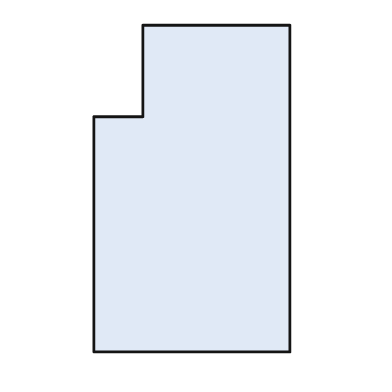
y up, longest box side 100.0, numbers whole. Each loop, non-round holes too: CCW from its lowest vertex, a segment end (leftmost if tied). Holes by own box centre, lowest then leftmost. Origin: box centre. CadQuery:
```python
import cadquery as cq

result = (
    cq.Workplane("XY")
    .moveTo(-30.0, -50.0)
    .lineTo(30.0, -50.0)
    .lineTo(30.0, 50.0)
    .lineTo(-15.0, 50.0)
    .lineTo(-15.0, 22.0)
    .lineTo(-30.0, 22.0)
    .close()
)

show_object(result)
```